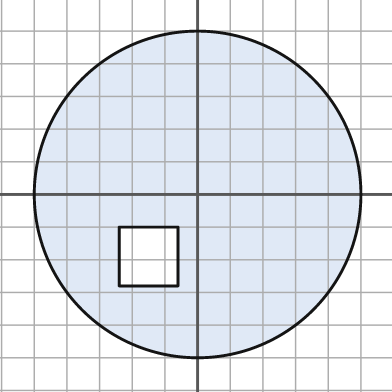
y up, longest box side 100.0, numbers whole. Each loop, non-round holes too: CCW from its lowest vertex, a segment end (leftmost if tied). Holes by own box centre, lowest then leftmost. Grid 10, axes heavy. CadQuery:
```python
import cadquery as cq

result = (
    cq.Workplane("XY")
    .moveTo(0.0, 0.0)
    .circle(50.0)
    .moveTo(-24.0, -28.0)
    .lineTo(-6.0, -28.0)
    .lineTo(-6.0, -10.0)
    .lineTo(-24.0, -10.0)
    .close()
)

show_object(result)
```